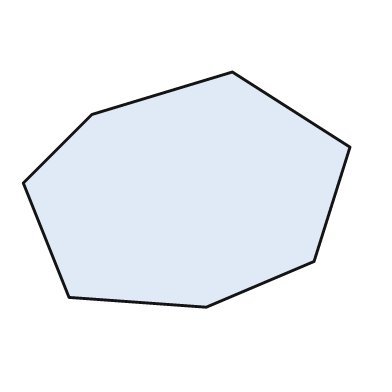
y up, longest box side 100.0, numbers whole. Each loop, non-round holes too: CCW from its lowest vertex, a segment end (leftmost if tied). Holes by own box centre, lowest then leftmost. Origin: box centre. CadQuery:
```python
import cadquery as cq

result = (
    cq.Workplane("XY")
    .moveTo(6.0, -36.0)
    .lineTo(39.0, -22.0)
    .lineTo(50.0, 13.0)
    .lineTo(14.0, 36.0)
    .lineTo(-29.0, 23.0)
    .lineTo(-50.0, 2.0)
    .lineTo(-36.0, -33.0)
    .close()
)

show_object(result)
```